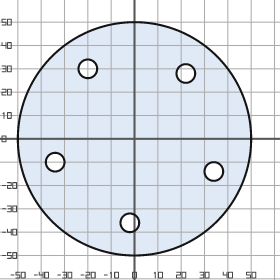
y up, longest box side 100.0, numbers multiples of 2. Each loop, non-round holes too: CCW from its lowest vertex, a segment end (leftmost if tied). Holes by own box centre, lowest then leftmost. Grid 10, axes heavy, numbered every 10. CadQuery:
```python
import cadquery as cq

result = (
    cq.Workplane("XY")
    .moveTo(0.0, 0.0)
    .circle(50.0)
    .moveTo(-2.0, -36.0)
    .circle(4.0)
    .moveTo(34.0, -14.0)
    .circle(4.0)
    .moveTo(-34.0, -10.0)
    .circle(4.0)
    .moveTo(22.0, 28.0)
    .circle(4.0)
    .moveTo(-20.0, 30.0)
    .circle(4.0)
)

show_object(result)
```